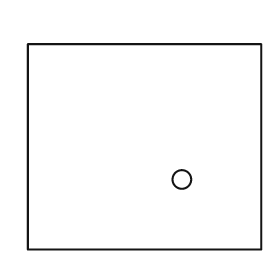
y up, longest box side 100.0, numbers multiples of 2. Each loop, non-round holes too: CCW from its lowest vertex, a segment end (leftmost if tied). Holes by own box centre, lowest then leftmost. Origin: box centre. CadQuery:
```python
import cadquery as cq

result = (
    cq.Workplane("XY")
    .moveTo(-50.0, -44.0)
    .lineTo(50.0, -44.0)
    .lineTo(50.0, 44.0)
    .lineTo(-50.0, 44.0)
    .close()
    .moveTo(16.0, -14.0)
    .circle(4.0)
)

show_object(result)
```